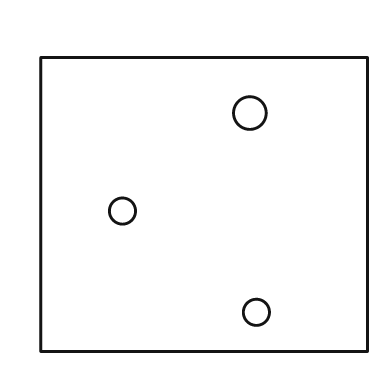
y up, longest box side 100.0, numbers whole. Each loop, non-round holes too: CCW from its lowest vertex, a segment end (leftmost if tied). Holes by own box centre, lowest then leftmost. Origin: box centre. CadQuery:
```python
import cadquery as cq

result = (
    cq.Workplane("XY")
    .moveTo(-50.0, -45.0)
    .lineTo(50.0, -45.0)
    .lineTo(50.0, 45.0)
    .lineTo(-50.0, 45.0)
    .close()
    .moveTo(16.0, -33.0)
    .circle(4.0)
    .moveTo(-25.0, -2.0)
    .circle(4.0)
    .moveTo(14.0, 28.0)
    .circle(5.0)
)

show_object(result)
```